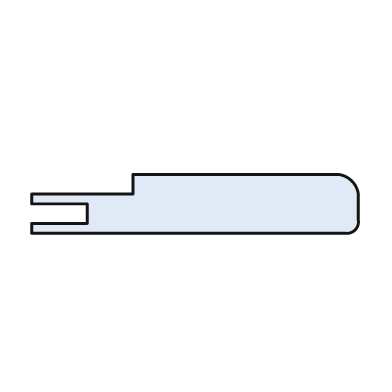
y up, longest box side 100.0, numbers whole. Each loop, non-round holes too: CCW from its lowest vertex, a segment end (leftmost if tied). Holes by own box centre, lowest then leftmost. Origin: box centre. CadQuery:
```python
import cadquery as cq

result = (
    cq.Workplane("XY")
    .moveTo(-50.0, -9.0)
    .lineTo(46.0, -9.0)
    .threePointArc((49.0, -8.0), (50.0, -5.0))
    .lineTo(50.0, 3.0)
    .threePointArc((48.0, 7.0), (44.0, 9.0))
    .lineTo(-19.0, 9.0)
    .lineTo(-19.0, 3.0)
    .lineTo(-50.0, 3.0)
    .lineTo(-50.0, 0.0)
    .lineTo(-33.0, 0.0)
    .lineTo(-33.0, -6.0)
    .lineTo(-50.0, -6.0)
    .close()
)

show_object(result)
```